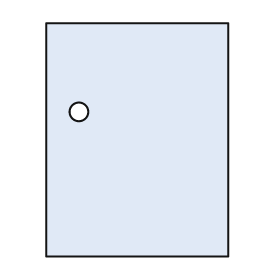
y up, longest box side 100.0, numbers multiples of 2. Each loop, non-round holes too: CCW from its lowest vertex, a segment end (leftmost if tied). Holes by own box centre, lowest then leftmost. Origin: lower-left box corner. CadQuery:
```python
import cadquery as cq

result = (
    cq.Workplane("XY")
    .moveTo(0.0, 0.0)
    .lineTo(78.0, 0.0)
    .lineTo(78.0, 100.0)
    .lineTo(0.0, 100.0)
    .close()
    .moveTo(14.0, 62.0)
    .circle(4.0)
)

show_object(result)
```